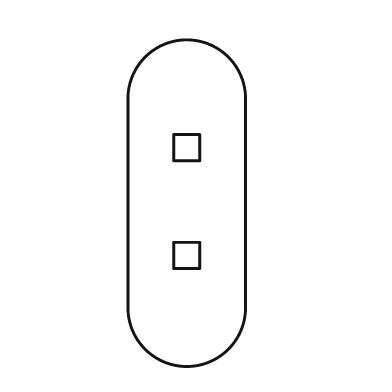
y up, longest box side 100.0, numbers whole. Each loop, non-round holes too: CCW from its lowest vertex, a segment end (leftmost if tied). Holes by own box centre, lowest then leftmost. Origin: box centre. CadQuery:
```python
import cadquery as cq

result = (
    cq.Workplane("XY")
    .moveTo(-18.0, -32.0)
    .threePointArc((0.0, -50.0), (18.0, -32.0))
    .lineTo(18.0, 32.0)
    .threePointArc((0.0, 50.0), (-18.0, 32.0))
    .close()
    .moveTo(-4.0, -20.0)
    .lineTo(4.0, -20.0)
    .lineTo(4.0, -12.0)
    .lineTo(-4.0, -12.0)
    .close()
    .moveTo(-4.0, 13.0)
    .lineTo(4.0, 13.0)
    .lineTo(4.0, 21.0)
    .lineTo(-4.0, 21.0)
    .close()
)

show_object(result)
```